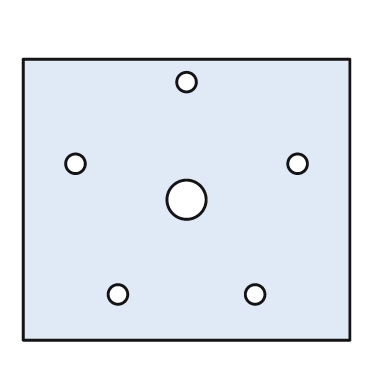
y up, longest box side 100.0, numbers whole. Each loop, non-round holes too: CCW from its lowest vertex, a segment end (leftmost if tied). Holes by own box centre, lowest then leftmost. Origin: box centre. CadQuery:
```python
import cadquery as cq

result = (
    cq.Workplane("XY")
    .moveTo(-50.0, -43.0)
    .lineTo(50.0, -43.0)
    .lineTo(50.0, 43.0)
    .lineTo(-50.0, 43.0)
    .close()
    .moveTo(-21.0, -29.0)
    .circle(3.0)
    .moveTo(21.0, -29.0)
    .circle(3.0)
    .moveTo(0.0, 0.0)
    .circle(6.0)
    .moveTo(-34.0, 11.0)
    .circle(3.0)
    .moveTo(34.0, 11.0)
    .circle(3.0)
    .moveTo(0.0, 36.0)
    .circle(3.0)
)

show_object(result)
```